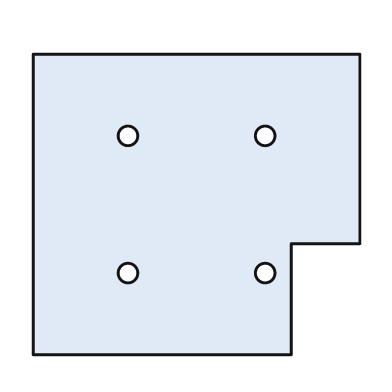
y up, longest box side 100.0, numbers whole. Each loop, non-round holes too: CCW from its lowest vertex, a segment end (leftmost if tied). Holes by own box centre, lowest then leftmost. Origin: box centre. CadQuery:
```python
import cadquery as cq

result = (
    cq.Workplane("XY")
    .moveTo(-50.0, -46.0)
    .lineTo(29.0, -46.0)
    .lineTo(29.0, -12.0)
    .lineTo(50.0, -12.0)
    .lineTo(50.0, 46.0)
    .lineTo(-50.0, 46.0)
    .close()
    .moveTo(-21.0, -21.0)
    .circle(3.0)
    .moveTo(21.0, -21.0)
    .circle(3.0)
    .moveTo(-21.0, 21.0)
    .circle(3.0)
    .moveTo(21.0, 21.0)
    .circle(3.0)
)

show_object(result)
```